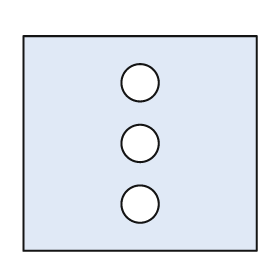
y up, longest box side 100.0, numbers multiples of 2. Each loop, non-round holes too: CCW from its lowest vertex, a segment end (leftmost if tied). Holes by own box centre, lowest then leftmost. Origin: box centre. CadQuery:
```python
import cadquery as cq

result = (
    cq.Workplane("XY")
    .moveTo(-50.0, -46.0)
    .lineTo(50.0, -46.0)
    .lineTo(50.0, 46.0)
    .lineTo(-50.0, 46.0)
    .close()
    .moveTo(0.0, -26.0)
    .circle(8.0)
    .moveTo(0.0, 0.0)
    .circle(8.0)
    .moveTo(0.0, 26.0)
    .circle(8.0)
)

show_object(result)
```